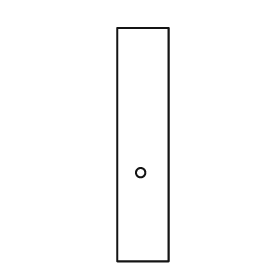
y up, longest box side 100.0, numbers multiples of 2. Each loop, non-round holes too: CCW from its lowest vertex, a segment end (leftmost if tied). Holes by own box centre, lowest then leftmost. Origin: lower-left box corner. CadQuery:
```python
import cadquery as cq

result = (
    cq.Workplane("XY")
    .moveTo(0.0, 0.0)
    .lineTo(22.0, 0.0)
    .lineTo(22.0, 100.0)
    .lineTo(0.0, 100.0)
    .close()
    .moveTo(10.0, 38.0)
    .circle(2.0)
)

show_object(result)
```